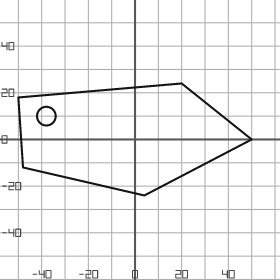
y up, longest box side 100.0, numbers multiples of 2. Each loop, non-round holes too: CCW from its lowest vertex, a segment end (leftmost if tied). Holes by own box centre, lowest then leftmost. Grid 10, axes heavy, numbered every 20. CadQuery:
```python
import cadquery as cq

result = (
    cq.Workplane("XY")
    .moveTo(4.0, -24.0)
    .lineTo(50.0, 0.0)
    .lineTo(20.0, 24.0)
    .lineTo(-50.0, 18.0)
    .lineTo(-48.0, -12.0)
    .close()
    .moveTo(-38.0, 10.0)
    .circle(4.0)
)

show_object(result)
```